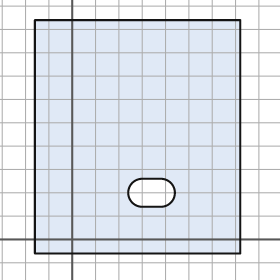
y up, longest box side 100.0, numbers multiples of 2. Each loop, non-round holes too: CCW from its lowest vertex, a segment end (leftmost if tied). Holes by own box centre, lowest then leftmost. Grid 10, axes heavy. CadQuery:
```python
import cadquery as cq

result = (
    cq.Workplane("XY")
    .moveTo(-16.0, -6.0)
    .lineTo(72.0, -6.0)
    .lineTo(72.0, 94.0)
    .lineTo(-16.0, 94.0)
    .close()
    .moveTo(30.0, 14.0)
    .lineTo(38.0, 14.0)
    .threePointArc((44.0, 20.0), (38.0, 26.0))
    .lineTo(30.0, 26.0)
    .threePointArc((24.0, 20.0), (30.0, 14.0))
    .close()
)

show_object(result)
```